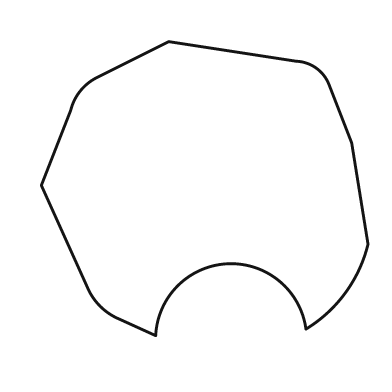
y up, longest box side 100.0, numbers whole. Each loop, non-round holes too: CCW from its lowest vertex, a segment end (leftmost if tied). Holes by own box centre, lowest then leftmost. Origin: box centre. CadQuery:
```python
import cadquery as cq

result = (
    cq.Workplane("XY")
    .moveTo(-15.0, -45.0)
    .threePointArc((7.0, -23.0), (31.0, -43.0))
    .threePointArc((43.0, -32.0), (50.0, -17.0))
    .lineTo(45.0, 14.0)
    .lineTo(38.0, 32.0)
    .threePointArc((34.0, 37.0), (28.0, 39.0))
    .lineTo(-11.0, 45.0)
    .lineTo(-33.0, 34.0)
    .threePointArc((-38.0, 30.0), (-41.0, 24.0))
    .lineTo(-50.0, 1.0)
    .lineTo(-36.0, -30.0)
    .threePointArc((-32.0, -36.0), (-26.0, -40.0))
    .close()
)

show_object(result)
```